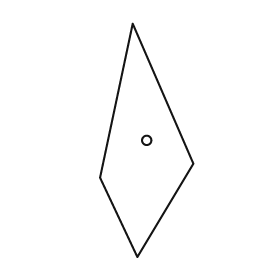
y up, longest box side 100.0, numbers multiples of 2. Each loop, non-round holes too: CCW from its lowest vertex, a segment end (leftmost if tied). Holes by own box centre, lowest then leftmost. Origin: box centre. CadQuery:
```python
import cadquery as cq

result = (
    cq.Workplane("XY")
    .moveTo(-4.0, -50.0)
    .lineTo(20.0, -10.0)
    .lineTo(-6.0, 50.0)
    .lineTo(-20.0, -16.0)
    .close()
    .moveTo(0.0, 0.0)
    .circle(2.0)
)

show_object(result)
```